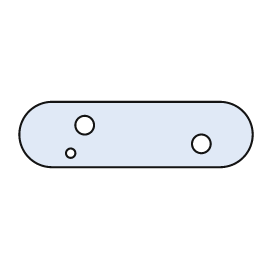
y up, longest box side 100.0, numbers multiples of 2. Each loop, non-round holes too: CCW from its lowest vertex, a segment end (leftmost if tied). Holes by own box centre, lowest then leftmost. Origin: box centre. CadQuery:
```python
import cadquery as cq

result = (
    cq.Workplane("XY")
    .moveTo(-36.0, -14.0)
    .lineTo(36.0, -14.0)
    .threePointArc((50.0, 0.0), (36.0, 14.0))
    .lineTo(-36.0, 14.0)
    .threePointArc((-50.0, 0.0), (-36.0, -14.0))
    .close()
    .moveTo(-28.0, -8.0)
    .circle(2.0)
    .moveTo(28.0, -4.0)
    .circle(4.0)
    .moveTo(-22.0, 4.0)
    .circle(4.0)
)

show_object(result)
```